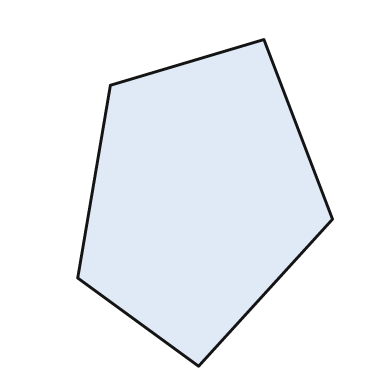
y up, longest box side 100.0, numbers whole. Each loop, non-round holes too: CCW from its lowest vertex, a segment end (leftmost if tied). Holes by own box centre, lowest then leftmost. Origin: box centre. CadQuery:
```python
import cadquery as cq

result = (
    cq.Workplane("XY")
    .moveTo(-2.0, -50.0)
    .lineTo(39.0, -5.0)
    .lineTo(18.0, 50.0)
    .lineTo(-29.0, 36.0)
    .lineTo(-39.0, -23.0)
    .close()
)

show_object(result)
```